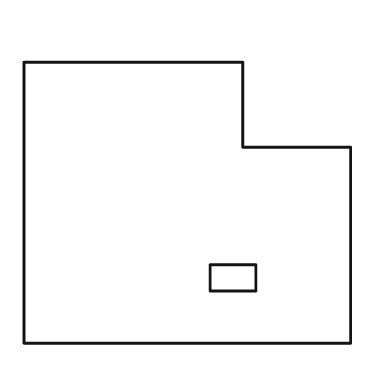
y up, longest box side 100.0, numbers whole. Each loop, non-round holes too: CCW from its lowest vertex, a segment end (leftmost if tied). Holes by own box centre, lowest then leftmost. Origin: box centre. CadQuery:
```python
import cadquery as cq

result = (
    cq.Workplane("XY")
    .moveTo(-50.0, -43.0)
    .lineTo(50.0, -43.0)
    .lineTo(50.0, 17.0)
    .lineTo(17.0, 17.0)
    .lineTo(17.0, 43.0)
    .lineTo(-50.0, 43.0)
    .close()
    .moveTo(7.0, -27.0)
    .lineTo(21.0, -27.0)
    .lineTo(21.0, -19.0)
    .lineTo(7.0, -19.0)
    .close()
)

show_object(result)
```